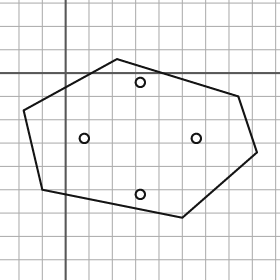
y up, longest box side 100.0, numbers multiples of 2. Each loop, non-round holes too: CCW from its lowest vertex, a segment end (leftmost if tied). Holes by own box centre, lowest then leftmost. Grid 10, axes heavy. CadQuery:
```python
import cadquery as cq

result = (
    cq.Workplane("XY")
    .moveTo(50.0, -62.0)
    .lineTo(82.0, -34.0)
    .lineTo(74.0, -10.0)
    .lineTo(22.0, 6.0)
    .lineTo(-18.0, -16.0)
    .lineTo(-10.0, -50.0)
    .close()
    .moveTo(32.0, -52.0)
    .circle(2.0)
    .moveTo(8.0, -28.0)
    .circle(2.0)
    .moveTo(56.0, -28.0)
    .circle(2.0)
    .moveTo(32.0, -4.0)
    .circle(2.0)
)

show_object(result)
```